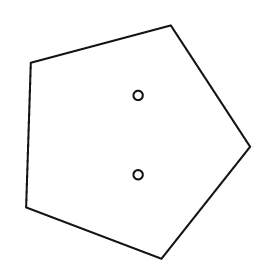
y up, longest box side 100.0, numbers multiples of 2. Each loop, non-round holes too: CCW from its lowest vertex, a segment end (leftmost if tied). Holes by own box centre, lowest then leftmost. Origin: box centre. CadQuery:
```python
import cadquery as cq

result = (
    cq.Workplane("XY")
    .moveTo(10.0, -50.0)
    .lineTo(48.0, -2.0)
    .lineTo(14.0, 50.0)
    .lineTo(-46.0, 34.0)
    .lineTo(-48.0, -28.0)
    .close()
    .moveTo(0.0, -14.0)
    .circle(2.0)
    .moveTo(0.0, 20.0)
    .circle(2.0)
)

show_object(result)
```